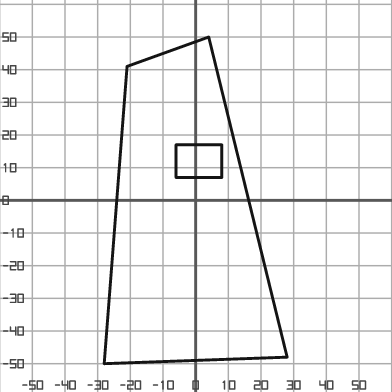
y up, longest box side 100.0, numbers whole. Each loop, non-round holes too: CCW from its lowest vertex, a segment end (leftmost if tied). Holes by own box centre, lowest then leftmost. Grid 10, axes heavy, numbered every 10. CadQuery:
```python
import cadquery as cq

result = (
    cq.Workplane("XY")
    .moveTo(-28.0, -50.0)
    .lineTo(28.0, -48.0)
    .lineTo(4.0, 50.0)
    .lineTo(-21.0, 41.0)
    .close()
    .moveTo(-6.0, 7.0)
    .lineTo(8.0, 7.0)
    .lineTo(8.0, 17.0)
    .lineTo(-6.0, 17.0)
    .close()
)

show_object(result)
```